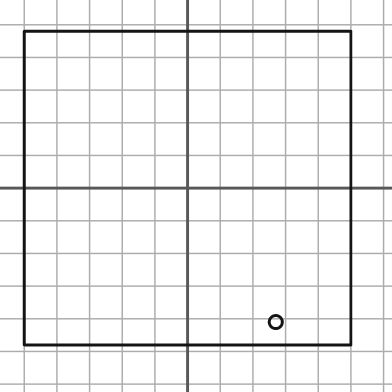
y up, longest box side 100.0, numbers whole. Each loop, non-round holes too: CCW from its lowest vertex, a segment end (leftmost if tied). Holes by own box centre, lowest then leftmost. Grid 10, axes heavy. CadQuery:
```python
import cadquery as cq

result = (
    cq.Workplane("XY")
    .moveTo(-50.0, -48.0)
    .lineTo(50.0, -48.0)
    .lineTo(50.0, 48.0)
    .lineTo(-50.0, 48.0)
    .close()
    .moveTo(27.0, -41.0)
    .circle(2.0)
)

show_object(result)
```